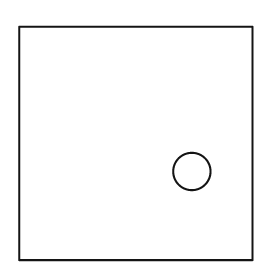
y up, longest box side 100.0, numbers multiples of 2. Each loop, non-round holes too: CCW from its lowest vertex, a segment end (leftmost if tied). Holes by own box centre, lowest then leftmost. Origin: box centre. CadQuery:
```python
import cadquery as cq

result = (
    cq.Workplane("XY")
    .moveTo(-50.0, -50.0)
    .lineTo(50.0, -50.0)
    .lineTo(50.0, 50.0)
    .lineTo(-50.0, 50.0)
    .close()
    .moveTo(24.0, -12.0)
    .circle(8.0)
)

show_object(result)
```